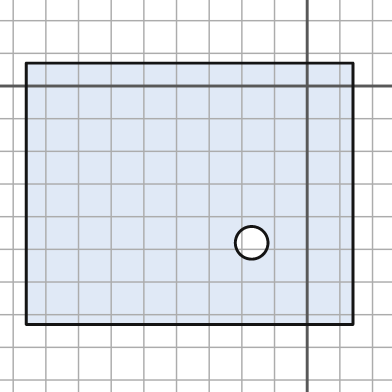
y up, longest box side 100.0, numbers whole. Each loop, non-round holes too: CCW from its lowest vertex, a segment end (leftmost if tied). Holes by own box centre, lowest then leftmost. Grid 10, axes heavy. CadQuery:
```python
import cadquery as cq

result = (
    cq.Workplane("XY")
    .moveTo(-86.0, -73.0)
    .lineTo(14.0, -73.0)
    .lineTo(14.0, 7.0)
    .lineTo(-86.0, 7.0)
    .close()
    .moveTo(-17.0, -48.0)
    .circle(5.0)
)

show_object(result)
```